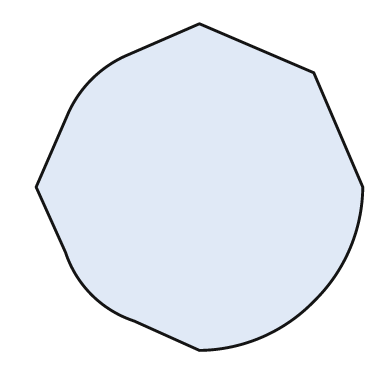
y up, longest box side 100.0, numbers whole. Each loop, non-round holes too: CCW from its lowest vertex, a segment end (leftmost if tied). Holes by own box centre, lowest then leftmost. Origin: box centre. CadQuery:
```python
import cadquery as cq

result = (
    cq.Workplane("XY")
    .moveTo(0.0, -50.0)
    .threePointArc((19.0, -46.0), (35.0, -35.0))
    .threePointArc((46.0, -19.0), (50.0, 0.0))
    .lineTo(35.0, 35.0)
    .lineTo(0.0, 50.0)
    .lineTo(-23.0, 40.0)
    .threePointArc((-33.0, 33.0), (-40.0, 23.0))
    .lineTo(-50.0, 0.0)
    .lineTo(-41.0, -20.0)
    .threePointArc((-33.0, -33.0), (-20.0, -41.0))
    .close()
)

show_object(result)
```